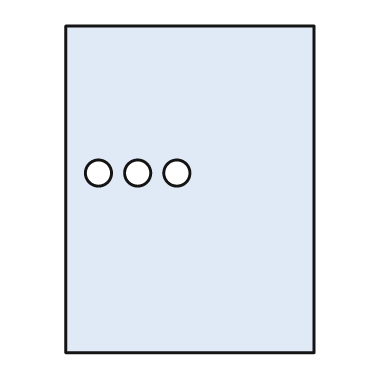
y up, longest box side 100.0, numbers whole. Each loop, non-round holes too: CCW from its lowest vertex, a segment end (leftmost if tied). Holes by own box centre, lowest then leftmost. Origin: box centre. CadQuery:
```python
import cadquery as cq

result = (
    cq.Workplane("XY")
    .moveTo(-38.0, -50.0)
    .lineTo(38.0, -50.0)
    .lineTo(38.0, 50.0)
    .lineTo(-38.0, 50.0)
    .close()
    .moveTo(-28.0, 5.0)
    .circle(4.0)
    .moveTo(-16.0, 5.0)
    .circle(4.0)
    .moveTo(-4.0, 5.0)
    .circle(4.0)
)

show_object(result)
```